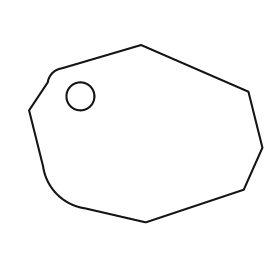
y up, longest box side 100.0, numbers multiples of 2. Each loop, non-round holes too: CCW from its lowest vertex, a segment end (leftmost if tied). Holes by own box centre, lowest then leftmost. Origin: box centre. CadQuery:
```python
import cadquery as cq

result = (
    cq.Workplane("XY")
    .moveTo(0.0, -38.0)
    .lineTo(42.0, -24.0)
    .lineTo(50.0, -6.0)
    .lineTo(44.0, 18.0)
    .lineTo(-2.0, 38.0)
    .lineTo(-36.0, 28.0)
    .threePointArc((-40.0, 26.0), (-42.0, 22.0))
    .lineTo(-50.0, 10.0)
    .lineTo(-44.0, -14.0)
    .threePointArc((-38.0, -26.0), (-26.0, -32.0))
    .close()
    .moveTo(-28.0, 16.0)
    .circle(6.0)
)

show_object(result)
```